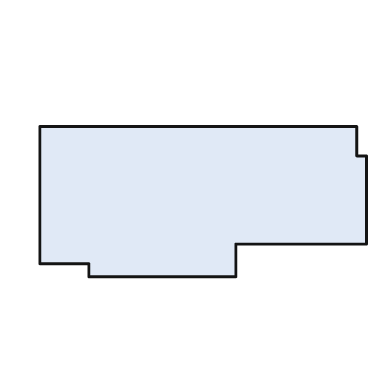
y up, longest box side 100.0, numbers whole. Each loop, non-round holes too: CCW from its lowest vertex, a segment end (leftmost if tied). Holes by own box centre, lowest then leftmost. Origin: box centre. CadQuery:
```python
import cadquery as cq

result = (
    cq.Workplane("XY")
    .moveTo(-35.0, -23.0)
    .lineTo(10.0, -23.0)
    .lineTo(10.0, -13.0)
    .lineTo(50.0, -13.0)
    .lineTo(50.0, 14.0)
    .lineTo(47.0, 14.0)
    .lineTo(47.0, 23.0)
    .lineTo(-50.0, 23.0)
    .lineTo(-50.0, -19.0)
    .lineTo(-35.0, -19.0)
    .close()
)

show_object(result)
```